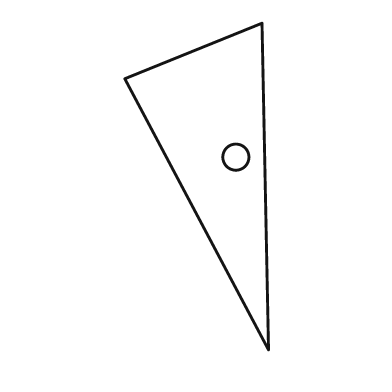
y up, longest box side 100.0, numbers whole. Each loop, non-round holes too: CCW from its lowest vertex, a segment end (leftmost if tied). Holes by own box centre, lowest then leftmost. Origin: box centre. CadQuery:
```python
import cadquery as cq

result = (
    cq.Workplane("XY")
    .moveTo(22.0, -50.0)
    .lineTo(20.0, 50.0)
    .lineTo(-22.0, 33.0)
    .close()
    .moveTo(12.0, 9.0)
    .circle(4.0)
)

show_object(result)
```